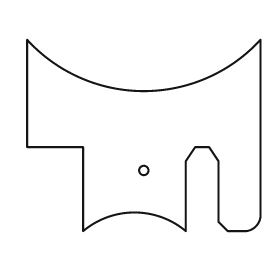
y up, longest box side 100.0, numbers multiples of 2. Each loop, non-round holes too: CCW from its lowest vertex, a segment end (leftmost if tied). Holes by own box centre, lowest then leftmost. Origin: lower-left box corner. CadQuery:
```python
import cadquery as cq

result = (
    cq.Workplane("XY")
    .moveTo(24.0, 0.0)
    .threePointArc((46.0, 8.0), (68.0, 0.0))
    .lineTo(68.0, 30.0)
    .lineTo(72.0, 36.0)
    .lineTo(78.0, 36.0)
    .lineTo(82.0, 30.0)
    .lineTo(82.0, 4.0)
    .lineTo(86.0, 0.0)
    .lineTo(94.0, 0.0)
    .threePointArc((98.0, 2.0), (100.0, 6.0))
    .lineTo(100.0, 82.0)
    .threePointArc((50.0, 60.0), (0.0, 82.0))
    .lineTo(0.0, 36.0)
    .lineTo(24.0, 36.0)
    .close()
    .moveTo(50.0, 26.0)
    .circle(2.0)
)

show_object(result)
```